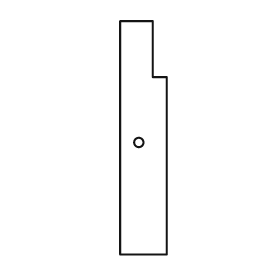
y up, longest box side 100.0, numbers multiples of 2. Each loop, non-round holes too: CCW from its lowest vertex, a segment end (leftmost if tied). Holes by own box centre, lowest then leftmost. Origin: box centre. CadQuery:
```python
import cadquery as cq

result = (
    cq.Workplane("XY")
    .moveTo(-10.0, -50.0)
    .lineTo(10.0, -50.0)
    .lineTo(10.0, 26.0)
    .lineTo(4.0, 26.0)
    .lineTo(4.0, 50.0)
    .lineTo(-10.0, 50.0)
    .close()
    .moveTo(-2.0, -2.0)
    .circle(2.0)
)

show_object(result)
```